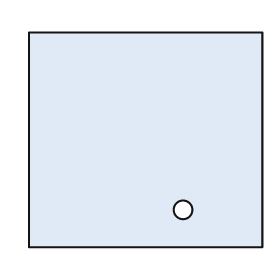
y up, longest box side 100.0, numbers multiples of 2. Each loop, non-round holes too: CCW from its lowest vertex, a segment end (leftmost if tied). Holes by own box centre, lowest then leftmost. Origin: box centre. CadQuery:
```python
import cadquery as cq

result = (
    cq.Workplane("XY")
    .moveTo(-50.0, -46.0)
    .lineTo(50.0, -46.0)
    .lineTo(50.0, 46.0)
    .lineTo(-50.0, 46.0)
    .close()
    .moveTo(16.0, -30.0)
    .circle(4.0)
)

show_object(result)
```